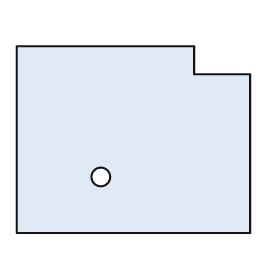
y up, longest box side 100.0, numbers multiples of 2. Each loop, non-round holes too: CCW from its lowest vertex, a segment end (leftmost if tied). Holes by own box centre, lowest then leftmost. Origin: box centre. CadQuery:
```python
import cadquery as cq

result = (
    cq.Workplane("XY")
    .moveTo(-50.0, -40.0)
    .lineTo(50.0, -40.0)
    .lineTo(50.0, 28.0)
    .lineTo(26.0, 28.0)
    .lineTo(26.0, 40.0)
    .lineTo(-50.0, 40.0)
    .close()
    .moveTo(-14.0, -16.0)
    .circle(4.0)
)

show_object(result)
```